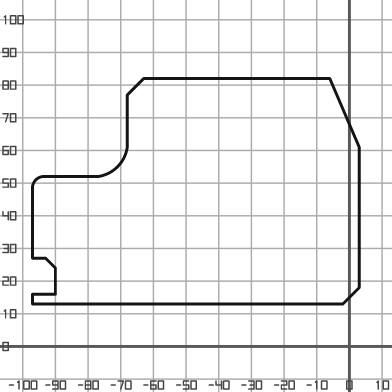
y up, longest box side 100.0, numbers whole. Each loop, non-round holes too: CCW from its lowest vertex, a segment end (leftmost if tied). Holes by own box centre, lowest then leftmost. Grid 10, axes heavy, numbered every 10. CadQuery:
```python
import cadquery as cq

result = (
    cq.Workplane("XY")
    .moveTo(-97.0, 13.0)
    .lineTo(-2.0, 13.0)
    .lineTo(3.0, 18.0)
    .lineTo(3.0, 61.0)
    .lineTo(-6.0, 82.0)
    .lineTo(-63.0, 82.0)
    .lineTo(-68.0, 77.0)
    .lineTo(-68.0, 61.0)
    .threePointArc((-71.0, 55.0), (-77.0, 52.0))
    .lineTo(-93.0, 52.0)
    .threePointArc((-96.0, 51.0), (-97.0, 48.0))
    .lineTo(-97.0, 27.0)
    .lineTo(-93.0, 27.0)
    .lineTo(-90.0, 24.0)
    .lineTo(-90.0, 16.0)
    .lineTo(-97.0, 16.0)
    .close()
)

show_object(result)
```